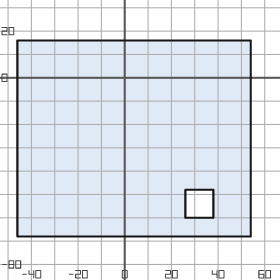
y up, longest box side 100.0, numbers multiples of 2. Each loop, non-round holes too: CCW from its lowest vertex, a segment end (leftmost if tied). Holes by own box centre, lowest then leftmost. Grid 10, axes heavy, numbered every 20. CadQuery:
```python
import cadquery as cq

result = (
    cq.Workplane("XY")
    .moveTo(-46.0, -68.0)
    .lineTo(54.0, -68.0)
    .lineTo(54.0, 16.0)
    .lineTo(-46.0, 16.0)
    .close()
    .moveTo(26.0, -60.0)
    .lineTo(38.0, -60.0)
    .lineTo(38.0, -48.0)
    .lineTo(26.0, -48.0)
    .close()
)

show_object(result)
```